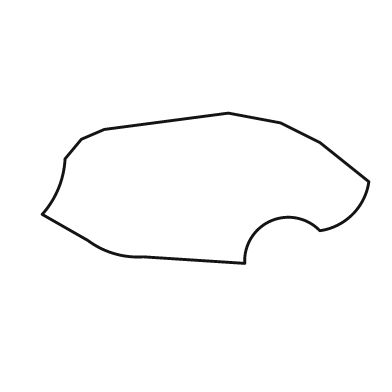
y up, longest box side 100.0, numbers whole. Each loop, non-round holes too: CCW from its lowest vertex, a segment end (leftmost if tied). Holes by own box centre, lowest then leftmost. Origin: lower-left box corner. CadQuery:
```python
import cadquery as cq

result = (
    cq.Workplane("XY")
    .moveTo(62.0, 0.0)
    .threePointArc((70.0, 13.0), (85.0, 10.0))
    .threePointArc((95.0, 15.0), (100.0, 25.0))
    .lineTo(85.0, 37.0)
    .lineTo(73.0, 43.0)
    .lineTo(57.0, 46.0)
    .lineTo(19.0, 41.0)
    .lineTo(12.0, 38.0)
    .lineTo(7.0, 32.0)
    .threePointArc((5.0, 23.0), (0.0, 15.0))
    .lineTo(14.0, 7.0)
    .threePointArc((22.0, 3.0), (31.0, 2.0))
    .close()
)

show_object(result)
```